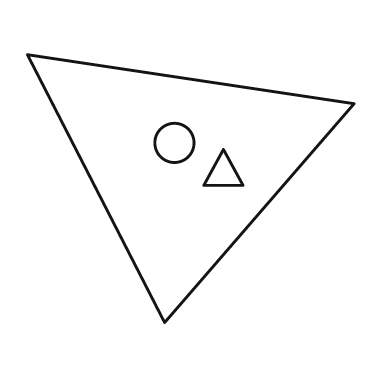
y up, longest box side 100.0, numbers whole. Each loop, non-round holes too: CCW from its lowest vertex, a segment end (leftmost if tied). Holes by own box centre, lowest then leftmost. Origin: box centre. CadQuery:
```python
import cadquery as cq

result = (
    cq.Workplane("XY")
    .moveTo(-8.0, -41.0)
    .lineTo(50.0, 26.0)
    .lineTo(-50.0, 41.0)
    .close()
    .moveTo(4.0, 1.0)
    .lineTo(16.0, 1.0)
    .lineTo(10.0, 12.0)
    .close()
    .moveTo(-5.0, 14.0)
    .circle(6.0)
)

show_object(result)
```